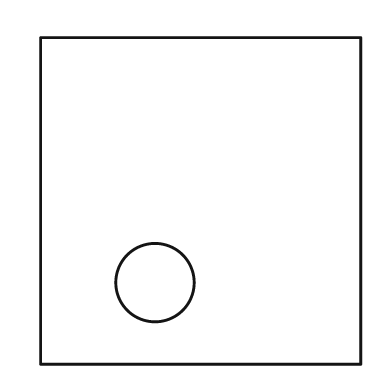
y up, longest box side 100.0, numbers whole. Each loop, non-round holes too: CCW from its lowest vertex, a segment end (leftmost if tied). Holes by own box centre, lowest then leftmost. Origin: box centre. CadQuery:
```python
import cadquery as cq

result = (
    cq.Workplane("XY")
    .moveTo(-49.0, -50.0)
    .lineTo(49.0, -50.0)
    .lineTo(49.0, 50.0)
    .lineTo(-49.0, 50.0)
    .close()
    .moveTo(-14.0, -25.0)
    .circle(12.0)
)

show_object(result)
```